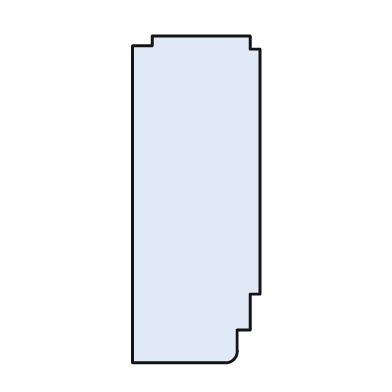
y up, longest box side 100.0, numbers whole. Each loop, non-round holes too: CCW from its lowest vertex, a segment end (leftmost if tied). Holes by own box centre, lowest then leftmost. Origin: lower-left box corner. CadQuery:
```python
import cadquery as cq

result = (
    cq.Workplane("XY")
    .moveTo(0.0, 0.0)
    .lineTo(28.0, 0.0)
    .threePointArc((31.0, 1.0), (32.0, 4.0))
    .lineTo(32.0, 10.0)
    .lineTo(36.0, 10.0)
    .lineTo(36.0, 21.0)
    .lineTo(39.0, 21.0)
    .lineTo(39.0, 96.0)
    .lineTo(36.0, 96.0)
    .lineTo(36.0, 100.0)
    .lineTo(6.0, 100.0)
    .lineTo(6.0, 97.0)
    .lineTo(0.0, 97.0)
    .close()
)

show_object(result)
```